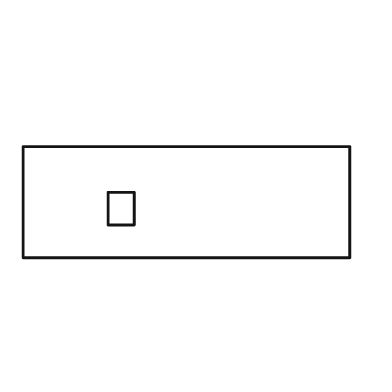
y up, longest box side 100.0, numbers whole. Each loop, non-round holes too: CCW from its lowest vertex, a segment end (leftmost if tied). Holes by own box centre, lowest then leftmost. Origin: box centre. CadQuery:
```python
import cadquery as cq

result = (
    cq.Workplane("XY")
    .moveTo(-50.0, -17.0)
    .lineTo(50.0, -17.0)
    .lineTo(50.0, 17.0)
    .lineTo(-50.0, 17.0)
    .close()
    .moveTo(-24.0, -7.0)
    .lineTo(-16.0, -7.0)
    .lineTo(-16.0, 3.0)
    .lineTo(-24.0, 3.0)
    .close()
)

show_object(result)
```